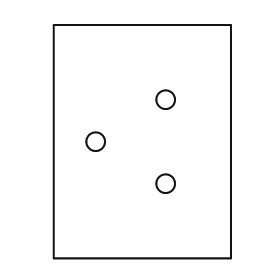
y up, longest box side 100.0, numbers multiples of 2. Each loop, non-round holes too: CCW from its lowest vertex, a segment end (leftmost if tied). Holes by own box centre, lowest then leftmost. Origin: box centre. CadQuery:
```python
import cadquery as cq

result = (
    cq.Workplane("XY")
    .moveTo(-38.0, -50.0)
    .lineTo(38.0, -50.0)
    .lineTo(38.0, 50.0)
    .lineTo(-38.0, 50.0)
    .close()
    .moveTo(10.0, -18.0)
    .circle(4.0)
    .moveTo(-20.0, 0.0)
    .circle(4.0)
    .moveTo(10.0, 18.0)
    .circle(4.0)
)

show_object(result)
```